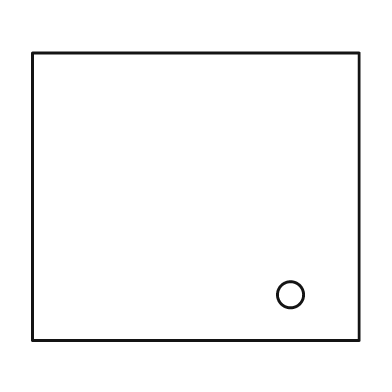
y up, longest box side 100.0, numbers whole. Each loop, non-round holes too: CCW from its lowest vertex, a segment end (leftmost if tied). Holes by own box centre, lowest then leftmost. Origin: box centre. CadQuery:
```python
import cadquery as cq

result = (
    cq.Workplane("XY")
    .moveTo(-50.0, -44.0)
    .lineTo(50.0, -44.0)
    .lineTo(50.0, 44.0)
    .lineTo(-50.0, 44.0)
    .close()
    .moveTo(29.0, -30.0)
    .circle(4.0)
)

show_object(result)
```